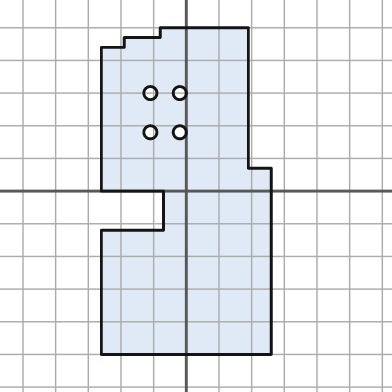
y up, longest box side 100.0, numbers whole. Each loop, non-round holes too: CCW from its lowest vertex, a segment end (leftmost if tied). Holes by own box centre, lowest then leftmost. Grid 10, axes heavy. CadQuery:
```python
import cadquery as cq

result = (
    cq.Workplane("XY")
    .moveTo(-26.0, -50.0)
    .lineTo(26.0, -50.0)
    .lineTo(26.0, 7.0)
    .lineTo(19.0, 7.0)
    .lineTo(19.0, 50.0)
    .lineTo(-8.0, 50.0)
    .lineTo(-8.0, 47.0)
    .lineTo(-19.0, 47.0)
    .lineTo(-19.0, 44.0)
    .lineTo(-26.0, 44.0)
    .lineTo(-26.0, 0.0)
    .lineTo(-7.0, 0.0)
    .lineTo(-7.0, -12.0)
    .lineTo(-26.0, -12.0)
    .close()
    .moveTo(-11.0, 18.0)
    .circle(2.0)
    .moveTo(-2.0, 18.0)
    .circle(2.0)
    .moveTo(-11.0, 30.0)
    .circle(2.0)
    .moveTo(-2.0, 30.0)
    .circle(2.0)
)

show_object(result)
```